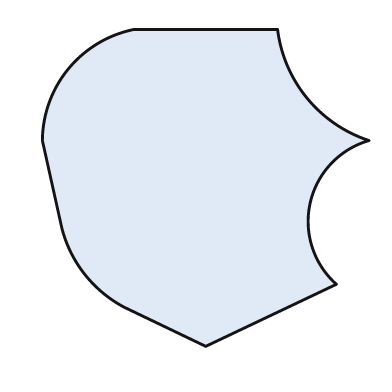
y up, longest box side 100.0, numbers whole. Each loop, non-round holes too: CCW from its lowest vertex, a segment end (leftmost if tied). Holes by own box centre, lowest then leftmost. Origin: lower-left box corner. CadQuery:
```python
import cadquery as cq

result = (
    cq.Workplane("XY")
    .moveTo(50.0, 0.0)
    .lineTo(90.0, 19.0)
    .threePointArc((82.0, 44.0), (100.0, 63.0))
    .threePointArc((81.0, 76.0), (72.0, 97.0))
    .lineTo(28.0, 97.0)
    .threePointArc((8.0, 85.0), (0.0, 63.0))
    .lineTo(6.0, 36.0)
    .threePointArc((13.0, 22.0), (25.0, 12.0))
    .close()
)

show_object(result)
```